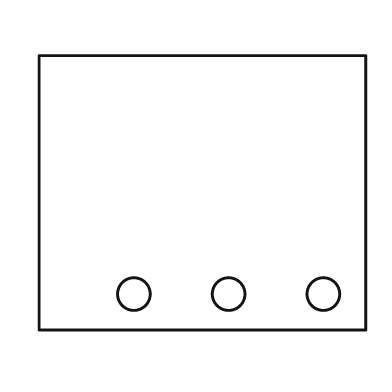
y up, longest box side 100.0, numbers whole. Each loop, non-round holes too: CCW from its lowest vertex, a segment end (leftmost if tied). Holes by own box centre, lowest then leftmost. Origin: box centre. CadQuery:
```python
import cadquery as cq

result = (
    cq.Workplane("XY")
    .moveTo(-50.0, -42.0)
    .lineTo(50.0, -42.0)
    .lineTo(50.0, 42.0)
    .lineTo(-50.0, 42.0)
    .close()
    .moveTo(-21.0, -31.0)
    .circle(5.0)
    .moveTo(8.0, -31.0)
    .circle(5.0)
    .moveTo(37.0, -31.0)
    .circle(5.0)
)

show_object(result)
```